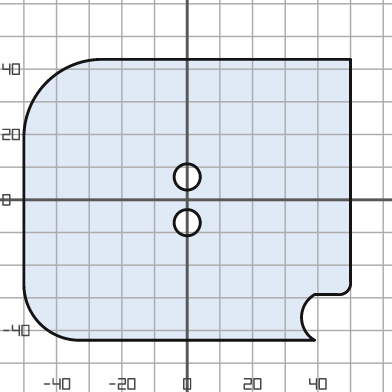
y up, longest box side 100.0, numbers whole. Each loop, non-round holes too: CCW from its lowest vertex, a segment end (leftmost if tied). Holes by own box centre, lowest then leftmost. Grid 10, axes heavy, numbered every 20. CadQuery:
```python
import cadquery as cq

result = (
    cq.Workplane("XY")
    .moveTo(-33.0, -43.0)
    .lineTo(39.0, -43.0)
    .threePointArc((35.0, -36.0), (39.0, -29.0))
    .lineTo(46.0, -29.0)
    .threePointArc((49.0, -28.0), (50.0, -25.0))
    .lineTo(50.0, 43.0)
    .lineTo(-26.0, 43.0)
    .threePointArc((-43.0, 36.0), (-50.0, 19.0))
    .lineTo(-50.0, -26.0)
    .threePointArc((-45.0, -38.0), (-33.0, -43.0))
    .close()
    .moveTo(0.0, -7.0)
    .circle(4.0)
    .moveTo(0.0, 7.0)
    .circle(4.0)
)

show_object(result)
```